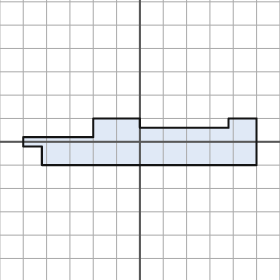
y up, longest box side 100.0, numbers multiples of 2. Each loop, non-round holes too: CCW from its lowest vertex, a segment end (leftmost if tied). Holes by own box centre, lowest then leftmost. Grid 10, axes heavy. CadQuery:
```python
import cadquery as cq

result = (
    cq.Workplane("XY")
    .moveTo(-42.0, -10.0)
    .lineTo(50.0, -10.0)
    .lineTo(50.0, 10.0)
    .lineTo(38.0, 10.0)
    .lineTo(38.0, 6.0)
    .lineTo(0.0, 6.0)
    .lineTo(0.0, 10.0)
    .lineTo(-20.0, 10.0)
    .lineTo(-20.0, 2.0)
    .lineTo(-50.0, 2.0)
    .lineTo(-50.0, -2.0)
    .lineTo(-42.0, -2.0)
    .close()
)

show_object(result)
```